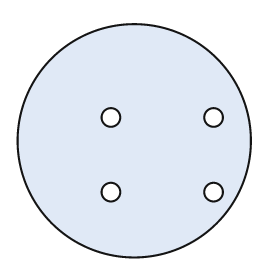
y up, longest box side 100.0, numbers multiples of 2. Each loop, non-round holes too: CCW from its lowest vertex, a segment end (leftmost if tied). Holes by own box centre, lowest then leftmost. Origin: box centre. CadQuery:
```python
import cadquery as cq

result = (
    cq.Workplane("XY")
    .moveTo(0.0, 0.0)
    .circle(50.0)
    .moveTo(-10.0, -22.0)
    .circle(4.0)
    .moveTo(34.0, -22.0)
    .circle(4.0)
    .moveTo(-10.0, 10.0)
    .circle(4.0)
    .moveTo(34.0, 10.0)
    .circle(4.0)
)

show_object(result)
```